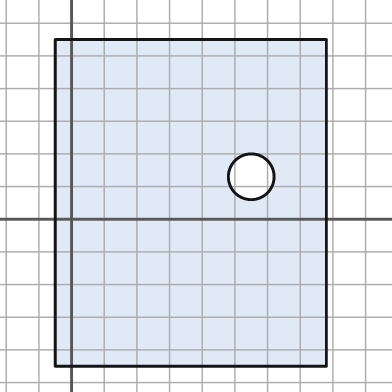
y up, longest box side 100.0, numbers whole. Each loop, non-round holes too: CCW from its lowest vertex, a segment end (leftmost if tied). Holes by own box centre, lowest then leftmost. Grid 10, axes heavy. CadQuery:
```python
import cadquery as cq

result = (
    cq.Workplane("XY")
    .moveTo(-5.0, -45.0)
    .lineTo(78.0, -45.0)
    .lineTo(78.0, 55.0)
    .lineTo(-5.0, 55.0)
    .close()
    .moveTo(55.0, 13.0)
    .circle(7.0)
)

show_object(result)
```